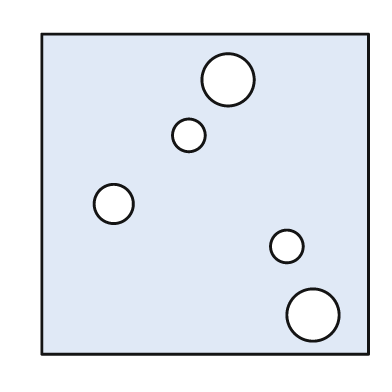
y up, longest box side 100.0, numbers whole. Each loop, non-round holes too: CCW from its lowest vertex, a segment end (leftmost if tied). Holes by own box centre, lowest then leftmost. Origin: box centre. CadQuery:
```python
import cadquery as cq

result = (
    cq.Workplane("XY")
    .moveTo(-50.0, -49.0)
    .lineTo(50.0, -49.0)
    .lineTo(50.0, 49.0)
    .lineTo(-50.0, 49.0)
    .close()
    .moveTo(33.0, -37.0)
    .circle(8.0)
    .moveTo(25.0, -16.0)
    .circle(5.0)
    .moveTo(-28.0, -3.0)
    .circle(6.0)
    .moveTo(-5.0, 18.0)
    .circle(5.0)
    .moveTo(7.0, 35.0)
    .circle(8.0)
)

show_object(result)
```